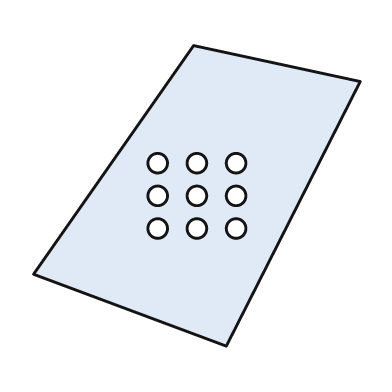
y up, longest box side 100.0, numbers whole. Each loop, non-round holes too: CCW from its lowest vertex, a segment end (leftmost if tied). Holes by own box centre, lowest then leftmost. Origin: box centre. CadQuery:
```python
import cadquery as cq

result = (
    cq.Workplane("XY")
    .moveTo(9.0, -46.0)
    .lineTo(50.0, 35.0)
    .lineTo(-1.0, 46.0)
    .lineTo(-50.0, -24.0)
    .close()
    .moveTo(-12.0, -10.0)
    .circle(3.0)
    .moveTo(0.0, -10.0)
    .circle(3.0)
    .moveTo(12.0, -10.0)
    .circle(3.0)
    .moveTo(-12.0, 0.0)
    .circle(3.0)
    .moveTo(0.0, 0.0)
    .circle(3.0)
    .moveTo(12.0, 0.0)
    .circle(3.0)
    .moveTo(-12.0, 10.0)
    .circle(3.0)
    .moveTo(0.0, 10.0)
    .circle(3.0)
    .moveTo(12.0, 10.0)
    .circle(3.0)
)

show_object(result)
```